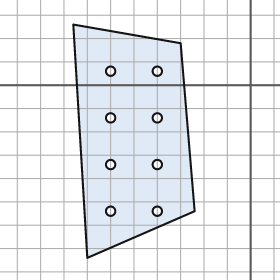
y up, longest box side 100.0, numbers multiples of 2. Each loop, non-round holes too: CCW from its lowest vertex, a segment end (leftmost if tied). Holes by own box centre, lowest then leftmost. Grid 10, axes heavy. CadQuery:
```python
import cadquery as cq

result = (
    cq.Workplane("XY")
    .moveTo(-70.0, -74.0)
    .lineTo(-24.0, -54.0)
    .lineTo(-30.0, 18.0)
    .lineTo(-76.0, 26.0)
    .close()
    .moveTo(-60.0, -54.0)
    .circle(2.0)
    .moveTo(-40.0, -54.0)
    .circle(2.0)
    .moveTo(-60.0, -34.0)
    .circle(2.0)
    .moveTo(-40.0, -34.0)
    .circle(2.0)
    .moveTo(-60.0, -14.0)
    .circle(2.0)
    .moveTo(-40.0, -14.0)
    .circle(2.0)
    .moveTo(-60.0, 6.0)
    .circle(2.0)
    .moveTo(-40.0, 6.0)
    .circle(2.0)
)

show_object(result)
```